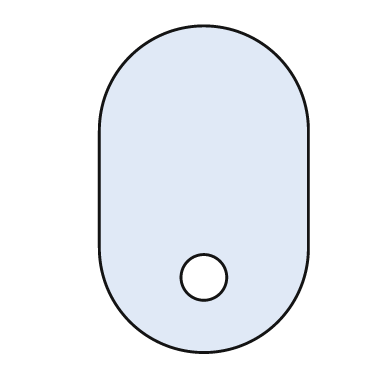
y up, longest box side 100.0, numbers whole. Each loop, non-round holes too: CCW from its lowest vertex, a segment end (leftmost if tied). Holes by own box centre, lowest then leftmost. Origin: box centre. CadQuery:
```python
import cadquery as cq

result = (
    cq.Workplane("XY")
    .moveTo(-32.0, -18.0)
    .threePointArc((0.0, -50.0), (32.0, -18.0))
    .lineTo(32.0, 18.0)
    .threePointArc((0.0, 50.0), (-32.0, 18.0))
    .close()
    .moveTo(0.0, -27.0)
    .circle(7.0)
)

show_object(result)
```